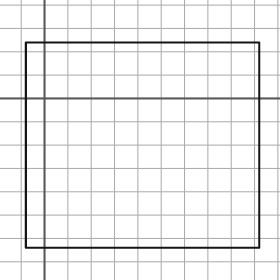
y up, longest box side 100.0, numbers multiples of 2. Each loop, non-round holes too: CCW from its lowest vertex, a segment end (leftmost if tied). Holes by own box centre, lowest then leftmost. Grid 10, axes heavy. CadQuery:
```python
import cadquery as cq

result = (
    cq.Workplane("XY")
    .moveTo(-8.0, -64.0)
    .lineTo(92.0, -64.0)
    .lineTo(92.0, 24.0)
    .lineTo(-8.0, 24.0)
    .close()
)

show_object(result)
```